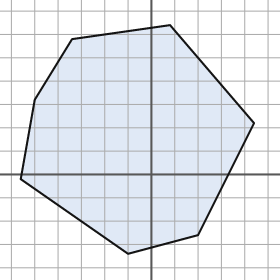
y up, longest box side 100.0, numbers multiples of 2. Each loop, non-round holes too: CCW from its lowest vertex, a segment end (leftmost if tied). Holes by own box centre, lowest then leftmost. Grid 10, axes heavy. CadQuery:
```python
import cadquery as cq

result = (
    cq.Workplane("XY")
    .moveTo(-10.0, -34.0)
    .lineTo(20.0, -26.0)
    .lineTo(44.0, 22.0)
    .lineTo(8.0, 64.0)
    .lineTo(-34.0, 58.0)
    .lineTo(-50.0, 32.0)
    .lineTo(-56.0, -2.0)
    .close()
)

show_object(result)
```